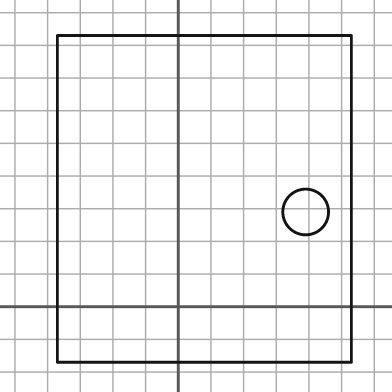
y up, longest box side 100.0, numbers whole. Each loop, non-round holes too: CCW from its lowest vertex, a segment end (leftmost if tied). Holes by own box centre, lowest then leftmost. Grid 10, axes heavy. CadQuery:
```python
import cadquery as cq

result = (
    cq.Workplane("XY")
    .moveTo(-37.0, -17.0)
    .lineTo(53.0, -17.0)
    .lineTo(53.0, 83.0)
    .lineTo(-37.0, 83.0)
    .close()
    .moveTo(39.0, 29.0)
    .circle(7.0)
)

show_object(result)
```